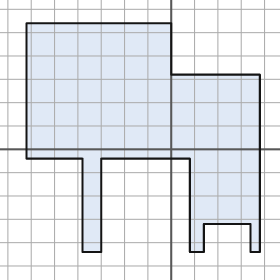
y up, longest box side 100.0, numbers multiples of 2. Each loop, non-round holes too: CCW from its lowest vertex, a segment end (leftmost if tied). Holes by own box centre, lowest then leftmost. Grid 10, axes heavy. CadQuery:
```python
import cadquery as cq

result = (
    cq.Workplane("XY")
    .moveTo(-38.0, -44.0)
    .lineTo(-30.0, -44.0)
    .lineTo(-30.0, -4.0)
    .lineTo(8.0, -4.0)
    .lineTo(8.0, -44.0)
    .lineTo(14.0, -44.0)
    .lineTo(14.0, -32.0)
    .lineTo(34.0, -32.0)
    .lineTo(34.0, -44.0)
    .lineTo(38.0, -44.0)
    .lineTo(38.0, 32.0)
    .lineTo(0.0, 32.0)
    .lineTo(0.0, 54.0)
    .lineTo(-62.0, 54.0)
    .lineTo(-62.0, -4.0)
    .lineTo(-38.0, -4.0)
    .close()
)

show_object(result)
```